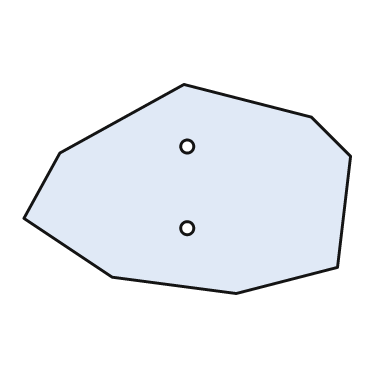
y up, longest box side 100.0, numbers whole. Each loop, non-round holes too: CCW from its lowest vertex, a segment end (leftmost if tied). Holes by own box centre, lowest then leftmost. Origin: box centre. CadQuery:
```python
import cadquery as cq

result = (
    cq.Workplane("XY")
    .moveTo(15.0, -32.0)
    .lineTo(46.0, -24.0)
    .lineTo(50.0, 10.0)
    .lineTo(38.0, 22.0)
    .lineTo(-1.0, 32.0)
    .lineTo(-39.0, 11.0)
    .lineTo(-50.0, -9.0)
    .lineTo(-23.0, -27.0)
    .close()
    .moveTo(0.0, -12.0)
    .circle(2.0)
    .moveTo(0.0, 13.0)
    .circle(2.0)
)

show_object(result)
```